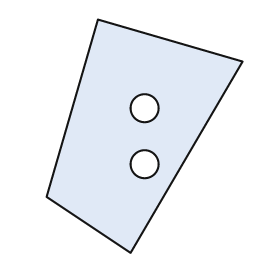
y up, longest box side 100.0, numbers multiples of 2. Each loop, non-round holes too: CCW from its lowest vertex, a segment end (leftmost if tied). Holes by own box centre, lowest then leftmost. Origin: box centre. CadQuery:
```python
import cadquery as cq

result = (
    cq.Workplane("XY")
    .moveTo(-6.0, -50.0)
    .lineTo(42.0, 32.0)
    .lineTo(-20.0, 50.0)
    .lineTo(-42.0, -26.0)
    .close()
    .moveTo(0.0, -12.0)
    .circle(6.0)
    .moveTo(0.0, 12.0)
    .circle(6.0)
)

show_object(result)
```